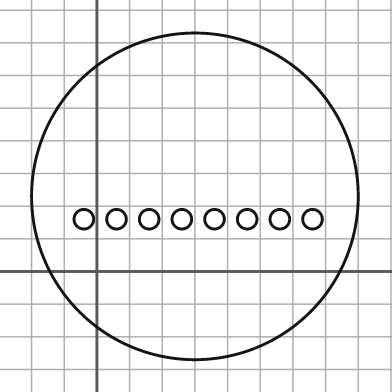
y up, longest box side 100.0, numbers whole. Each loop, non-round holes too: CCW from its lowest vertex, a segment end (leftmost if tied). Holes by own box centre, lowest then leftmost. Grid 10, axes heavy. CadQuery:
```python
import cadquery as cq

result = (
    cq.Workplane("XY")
    .moveTo(30.0, 23.0)
    .circle(50.0)
    .moveTo(-4.0, 16.0)
    .circle(3.0)
    .moveTo(6.0, 16.0)
    .circle(3.0)
    .moveTo(16.0, 16.0)
    .circle(3.0)
    .moveTo(26.0, 16.0)
    .circle(3.0)
    .moveTo(36.0, 16.0)
    .circle(3.0)
    .moveTo(46.0, 16.0)
    .circle(3.0)
    .moveTo(56.0, 16.0)
    .circle(3.0)
    .moveTo(66.0, 16.0)
    .circle(3.0)
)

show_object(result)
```